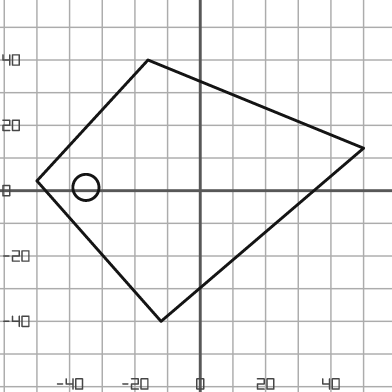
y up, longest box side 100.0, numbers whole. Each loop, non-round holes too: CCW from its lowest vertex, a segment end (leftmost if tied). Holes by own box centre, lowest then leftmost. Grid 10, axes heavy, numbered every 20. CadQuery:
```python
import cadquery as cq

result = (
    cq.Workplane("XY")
    .moveTo(-12.0, -40.0)
    .lineTo(50.0, 13.0)
    .lineTo(-16.0, 40.0)
    .lineTo(-50.0, 3.0)
    .close()
    .moveTo(-35.0, 1.0)
    .circle(4.0)
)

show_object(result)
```